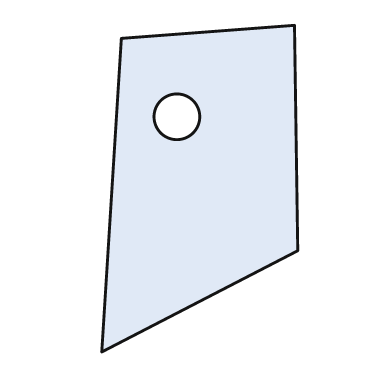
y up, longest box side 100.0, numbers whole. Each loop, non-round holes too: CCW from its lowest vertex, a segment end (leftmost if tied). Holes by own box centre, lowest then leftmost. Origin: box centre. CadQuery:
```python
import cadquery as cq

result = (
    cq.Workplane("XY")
    .moveTo(-30.0, -50.0)
    .lineTo(30.0, -19.0)
    .lineTo(29.0, 50.0)
    .lineTo(-24.0, 46.0)
    .close()
    .moveTo(-7.0, 22.0)
    .circle(7.0)
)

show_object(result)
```